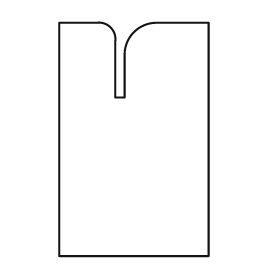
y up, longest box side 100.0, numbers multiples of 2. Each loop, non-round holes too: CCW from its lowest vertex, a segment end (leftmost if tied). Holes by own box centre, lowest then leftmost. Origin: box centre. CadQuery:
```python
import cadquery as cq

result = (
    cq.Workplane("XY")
    .moveTo(-32.0, -50.0)
    .lineTo(32.0, -50.0)
    .lineTo(32.0, 50.0)
    .lineTo(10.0, 50.0)
    .threePointArc((0.0, 46.0), (-4.0, 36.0))
    .lineTo(-4.0, 18.0)
    .lineTo(-8.0, 18.0)
    .lineTo(-8.0, 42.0)
    .threePointArc((-10.0, 48.0), (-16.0, 50.0))
    .lineTo(-32.0, 50.0)
    .close()
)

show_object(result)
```